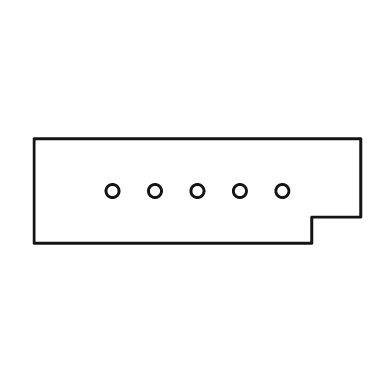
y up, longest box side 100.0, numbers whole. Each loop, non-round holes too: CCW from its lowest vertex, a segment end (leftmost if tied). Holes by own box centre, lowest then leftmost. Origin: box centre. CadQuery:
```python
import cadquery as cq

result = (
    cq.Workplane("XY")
    .moveTo(-50.0, -16.0)
    .lineTo(35.0, -16.0)
    .lineTo(35.0, -8.0)
    .lineTo(50.0, -8.0)
    .lineTo(50.0, 16.0)
    .lineTo(-50.0, 16.0)
    .close()
    .moveTo(-26.0, 0.0)
    .circle(2.0)
    .moveTo(-13.0, 0.0)
    .circle(2.0)
    .moveTo(0.0, 0.0)
    .circle(2.0)
    .moveTo(13.0, 0.0)
    .circle(2.0)
    .moveTo(26.0, 0.0)
    .circle(2.0)
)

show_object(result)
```